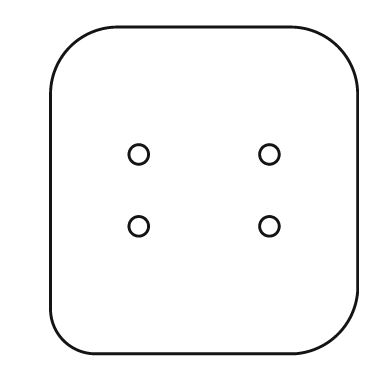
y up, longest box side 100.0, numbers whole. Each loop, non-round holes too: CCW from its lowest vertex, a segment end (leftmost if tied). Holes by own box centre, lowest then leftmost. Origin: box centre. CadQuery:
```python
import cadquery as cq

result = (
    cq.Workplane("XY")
    .moveTo(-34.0, -50.0)
    .lineTo(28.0, -50.0)
    .threePointArc((41.0, -44.0), (47.0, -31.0))
    .lineTo(47.0, 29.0)
    .threePointArc((41.0, 44.0), (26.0, 50.0))
    .lineTo(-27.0, 50.0)
    .threePointArc((-41.0, 44.0), (-47.0, 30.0))
    .lineTo(-47.0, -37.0)
    .threePointArc((-43.0, -46.0), (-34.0, -50.0))
    .close()
    .moveTo(-20.0, -11.0)
    .circle(3.0)
    .moveTo(20.0, -11.0)
    .circle(3.0)
    .moveTo(-20.0, 11.0)
    .circle(3.0)
    .moveTo(20.0, 11.0)
    .circle(3.0)
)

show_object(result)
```